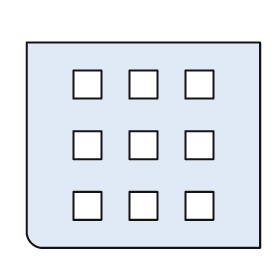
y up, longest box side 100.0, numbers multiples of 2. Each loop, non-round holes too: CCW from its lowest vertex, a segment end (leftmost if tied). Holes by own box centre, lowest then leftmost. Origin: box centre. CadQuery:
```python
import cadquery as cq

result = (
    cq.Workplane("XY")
    .moveTo(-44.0, -44.0)
    .lineTo(50.0, -44.0)
    .lineTo(50.0, 44.0)
    .lineTo(-50.0, 44.0)
    .lineTo(-50.0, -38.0)
    .threePointArc((-48.0, -42.0), (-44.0, -44.0))
    .close()
    .moveTo(-30.0, -32.0)
    .lineTo(-18.0, -32.0)
    .lineTo(-18.0, -20.0)
    .lineTo(-30.0, -20.0)
    .close()
    .moveTo(-6.0, -32.0)
    .lineTo(6.0, -32.0)
    .lineTo(6.0, -20.0)
    .lineTo(-6.0, -20.0)
    .close()
    .moveTo(18.0, -32.0)
    .lineTo(30.0, -32.0)
    .lineTo(30.0, -20.0)
    .lineTo(18.0, -20.0)
    .close()
    .moveTo(-30.0, -6.0)
    .lineTo(-18.0, -6.0)
    .lineTo(-18.0, 6.0)
    .lineTo(-30.0, 6.0)
    .close()
    .moveTo(-6.0, -6.0)
    .lineTo(6.0, -6.0)
    .lineTo(6.0, 6.0)
    .lineTo(-6.0, 6.0)
    .close()
    .moveTo(18.0, -6.0)
    .lineTo(30.0, -6.0)
    .lineTo(30.0, 6.0)
    .lineTo(18.0, 6.0)
    .close()
    .moveTo(-30.0, 20.0)
    .lineTo(-18.0, 20.0)
    .lineTo(-18.0, 32.0)
    .lineTo(-30.0, 32.0)
    .close()
    .moveTo(-6.0, 20.0)
    .lineTo(6.0, 20.0)
    .lineTo(6.0, 32.0)
    .lineTo(-6.0, 32.0)
    .close()
    .moveTo(18.0, 20.0)
    .lineTo(30.0, 20.0)
    .lineTo(30.0, 32.0)
    .lineTo(18.0, 32.0)
    .close()
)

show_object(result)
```